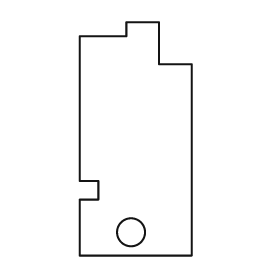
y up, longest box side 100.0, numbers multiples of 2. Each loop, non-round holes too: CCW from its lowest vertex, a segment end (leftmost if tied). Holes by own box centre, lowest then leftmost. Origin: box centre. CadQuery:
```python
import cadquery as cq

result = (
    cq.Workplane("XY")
    .moveTo(-24.0, -50.0)
    .lineTo(24.0, -50.0)
    .lineTo(24.0, 32.0)
    .lineTo(10.0, 32.0)
    .lineTo(10.0, 50.0)
    .lineTo(-4.0, 50.0)
    .lineTo(-4.0, 44.0)
    .lineTo(-24.0, 44.0)
    .lineTo(-24.0, -18.0)
    .lineTo(-16.0, -18.0)
    .lineTo(-16.0, -26.0)
    .lineTo(-24.0, -26.0)
    .close()
    .moveTo(-2.0, -40.0)
    .circle(6.0)
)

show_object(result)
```